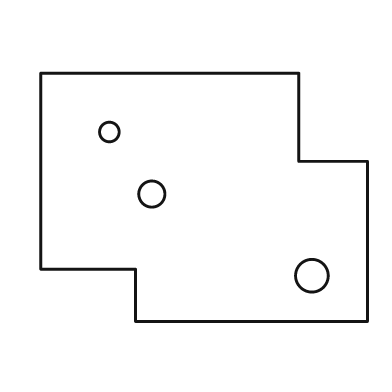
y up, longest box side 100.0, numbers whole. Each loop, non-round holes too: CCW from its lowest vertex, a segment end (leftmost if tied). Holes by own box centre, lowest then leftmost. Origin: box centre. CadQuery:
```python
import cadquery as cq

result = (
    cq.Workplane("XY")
    .moveTo(-21.0, -38.0)
    .lineTo(50.0, -38.0)
    .lineTo(50.0, 11.0)
    .lineTo(29.0, 11.0)
    .lineTo(29.0, 38.0)
    .lineTo(-50.0, 38.0)
    .lineTo(-50.0, -22.0)
    .lineTo(-21.0, -22.0)
    .close()
    .moveTo(33.0, -24.0)
    .circle(5.0)
    .moveTo(-16.0, 1.0)
    .circle(4.0)
    .moveTo(-29.0, 20.0)
    .circle(3.0)
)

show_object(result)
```